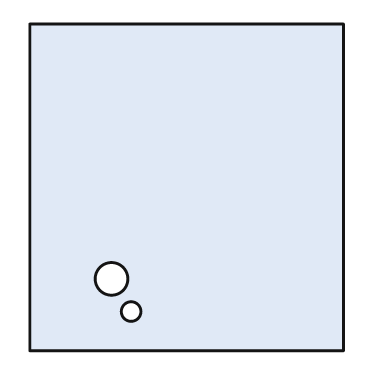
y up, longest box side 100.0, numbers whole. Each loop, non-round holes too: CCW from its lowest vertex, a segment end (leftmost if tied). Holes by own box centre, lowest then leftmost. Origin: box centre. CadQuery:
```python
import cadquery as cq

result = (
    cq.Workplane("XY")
    .moveTo(-48.0, -50.0)
    .lineTo(48.0, -50.0)
    .lineTo(48.0, 50.0)
    .lineTo(-48.0, 50.0)
    .close()
    .moveTo(-17.0, -38.0)
    .circle(3.0)
    .moveTo(-23.0, -28.0)
    .circle(5.0)
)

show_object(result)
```